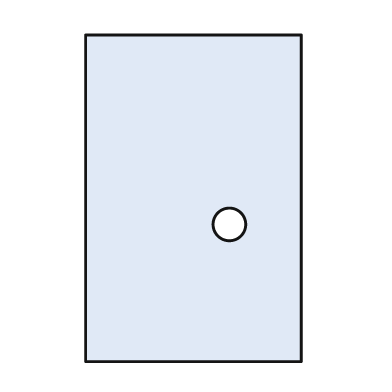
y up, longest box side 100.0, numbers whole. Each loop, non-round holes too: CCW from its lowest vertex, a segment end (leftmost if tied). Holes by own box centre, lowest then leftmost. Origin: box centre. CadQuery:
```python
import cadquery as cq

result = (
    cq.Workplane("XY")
    .moveTo(-33.0, -50.0)
    .lineTo(33.0, -50.0)
    .lineTo(33.0, 50.0)
    .lineTo(-33.0, 50.0)
    .close()
    .moveTo(11.0, -8.0)
    .circle(5.0)
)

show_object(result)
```